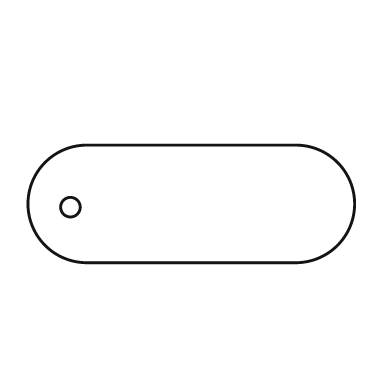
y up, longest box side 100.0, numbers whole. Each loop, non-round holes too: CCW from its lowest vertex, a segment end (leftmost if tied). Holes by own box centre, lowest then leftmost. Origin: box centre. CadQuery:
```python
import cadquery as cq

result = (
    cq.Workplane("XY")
    .moveTo(-32.0, -18.0)
    .lineTo(32.0, -18.0)
    .threePointArc((50.0, 0.0), (32.0, 18.0))
    .lineTo(-32.0, 18.0)
    .threePointArc((-50.0, 0.0), (-32.0, -18.0))
    .close()
    .moveTo(-37.0, -1.0)
    .circle(3.0)
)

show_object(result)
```